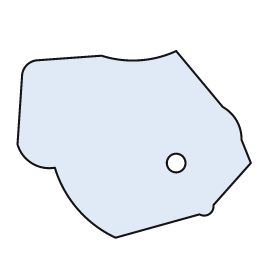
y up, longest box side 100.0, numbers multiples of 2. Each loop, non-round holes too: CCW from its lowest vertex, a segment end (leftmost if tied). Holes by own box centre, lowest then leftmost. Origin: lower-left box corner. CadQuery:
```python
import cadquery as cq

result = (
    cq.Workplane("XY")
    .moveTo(42.0, 0.0)
    .lineTo(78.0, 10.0)
    .threePointArc((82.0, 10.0), (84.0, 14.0))
    .lineTo(100.0, 32.0)
    .lineTo(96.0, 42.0)
    .threePointArc((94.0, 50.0), (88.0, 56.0))
    .lineTo(68.0, 80.0)
    .threePointArc((52.0, 76.0), (36.0, 78.0))
    .lineTo(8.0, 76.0)
    .threePointArc((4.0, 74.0), (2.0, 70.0))
    .lineTo(0.0, 40.0)
    .threePointArc((6.0, 32.0), (16.0, 30.0))
    .threePointArc((26.0, 12.0), (42.0, 0.0))
    .close()
    .moveTo(68.0, 32.0)
    .circle(4.0)
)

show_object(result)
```